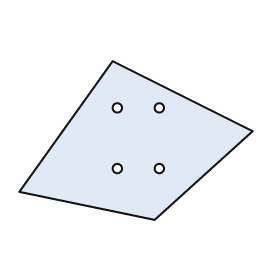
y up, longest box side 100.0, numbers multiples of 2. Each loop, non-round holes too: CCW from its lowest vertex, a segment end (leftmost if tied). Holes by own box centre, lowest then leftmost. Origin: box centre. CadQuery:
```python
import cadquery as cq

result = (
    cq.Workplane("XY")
    .moveTo(8.0, -34.0)
    .lineTo(50.0, 4.0)
    .lineTo(-10.0, 34.0)
    .lineTo(-50.0, -22.0)
    .close()
    .moveTo(-8.0, -12.0)
    .circle(2.0)
    .moveTo(10.0, -12.0)
    .circle(2.0)
    .moveTo(-8.0, 14.0)
    .circle(2.0)
    .moveTo(10.0, 14.0)
    .circle(2.0)
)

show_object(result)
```